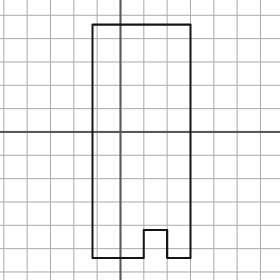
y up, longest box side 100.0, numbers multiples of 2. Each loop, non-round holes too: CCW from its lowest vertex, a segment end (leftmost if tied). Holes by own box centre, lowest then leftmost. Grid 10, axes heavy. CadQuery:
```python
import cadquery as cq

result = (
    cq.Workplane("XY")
    .moveTo(-12.0, -54.0)
    .lineTo(10.0, -54.0)
    .lineTo(10.0, -42.0)
    .lineTo(20.0, -42.0)
    .lineTo(20.0, -54.0)
    .lineTo(30.0, -54.0)
    .lineTo(30.0, 46.0)
    .lineTo(-12.0, 46.0)
    .close()
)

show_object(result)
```